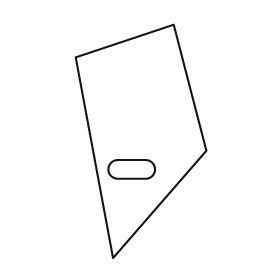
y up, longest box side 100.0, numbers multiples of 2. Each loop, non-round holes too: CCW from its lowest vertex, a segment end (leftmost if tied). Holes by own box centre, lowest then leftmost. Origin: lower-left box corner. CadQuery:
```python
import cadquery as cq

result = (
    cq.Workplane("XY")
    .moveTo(16.0, 0.0)
    .lineTo(56.0, 46.0)
    .lineTo(42.0, 100.0)
    .lineTo(0.0, 86.0)
    .close()
    .moveTo(18.0, 34.0)
    .lineTo(30.0, 34.0)
    .threePointArc((34.0, 38.0), (30.0, 42.0))
    .lineTo(18.0, 42.0)
    .threePointArc((14.0, 38.0), (18.0, 34.0))
    .close()
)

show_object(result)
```